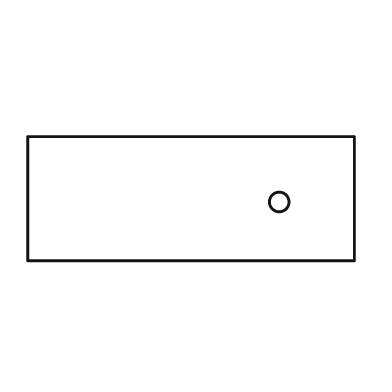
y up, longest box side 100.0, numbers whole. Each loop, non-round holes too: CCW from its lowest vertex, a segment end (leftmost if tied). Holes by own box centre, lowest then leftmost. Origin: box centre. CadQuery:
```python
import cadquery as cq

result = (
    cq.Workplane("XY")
    .moveTo(-50.0, -19.0)
    .lineTo(50.0, -19.0)
    .lineTo(50.0, 19.0)
    .lineTo(-50.0, 19.0)
    .close()
    .moveTo(27.0, -1.0)
    .circle(3.0)
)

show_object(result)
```